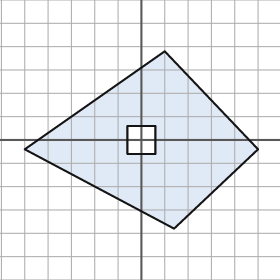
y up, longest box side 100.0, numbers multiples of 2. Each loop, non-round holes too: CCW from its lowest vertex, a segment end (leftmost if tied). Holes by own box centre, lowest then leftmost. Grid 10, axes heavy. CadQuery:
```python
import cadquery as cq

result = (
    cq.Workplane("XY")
    .moveTo(14.0, -38.0)
    .lineTo(50.0, -4.0)
    .lineTo(10.0, 38.0)
    .lineTo(-50.0, -4.0)
    .close()
    .moveTo(-6.0, -6.0)
    .lineTo(6.0, -6.0)
    .lineTo(6.0, 6.0)
    .lineTo(-6.0, 6.0)
    .close()
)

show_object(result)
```